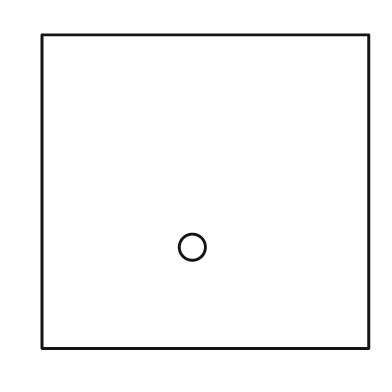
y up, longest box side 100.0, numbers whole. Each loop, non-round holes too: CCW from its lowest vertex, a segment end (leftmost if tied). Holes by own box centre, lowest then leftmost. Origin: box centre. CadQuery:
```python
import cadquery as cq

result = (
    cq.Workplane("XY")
    .moveTo(-50.0, -48.0)
    .lineTo(50.0, -48.0)
    .lineTo(50.0, 48.0)
    .lineTo(-50.0, 48.0)
    .close()
    .moveTo(-4.0, -17.0)
    .circle(4.0)
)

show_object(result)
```